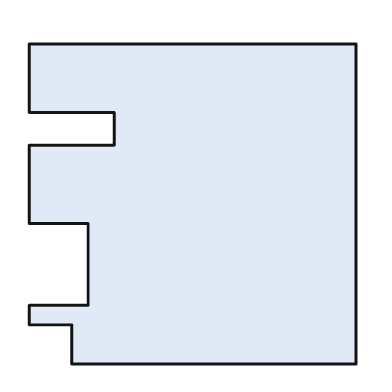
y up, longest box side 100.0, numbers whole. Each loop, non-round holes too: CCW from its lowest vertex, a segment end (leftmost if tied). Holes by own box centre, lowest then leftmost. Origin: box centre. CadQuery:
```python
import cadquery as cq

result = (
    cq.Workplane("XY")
    .moveTo(-37.0, -49.0)
    .lineTo(50.0, -49.0)
    .lineTo(50.0, 49.0)
    .lineTo(-50.0, 49.0)
    .lineTo(-50.0, 28.0)
    .lineTo(-24.0, 28.0)
    .lineTo(-24.0, 18.0)
    .lineTo(-50.0, 18.0)
    .lineTo(-50.0, -6.0)
    .lineTo(-32.0, -6.0)
    .lineTo(-32.0, -31.0)
    .lineTo(-50.0, -31.0)
    .lineTo(-50.0, -37.0)
    .lineTo(-37.0, -37.0)
    .close()
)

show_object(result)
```